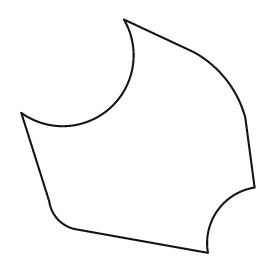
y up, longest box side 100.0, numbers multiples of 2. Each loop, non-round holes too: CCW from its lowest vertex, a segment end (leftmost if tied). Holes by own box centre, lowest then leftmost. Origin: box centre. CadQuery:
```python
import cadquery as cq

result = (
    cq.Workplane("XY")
    .moveTo(30.0, -50.0)
    .threePointArc((34.0, -32.0), (50.0, -22.0))
    .lineTo(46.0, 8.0)
    .threePointArc((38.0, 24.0), (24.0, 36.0))
    .lineTo(-6.0, 50.0)
    .threePointArc((-12.0, 12.0), (-50.0, 10.0))
    .lineTo(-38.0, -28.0)
    .threePointArc((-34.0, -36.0), (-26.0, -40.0))
    .close()
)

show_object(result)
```